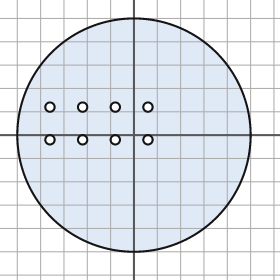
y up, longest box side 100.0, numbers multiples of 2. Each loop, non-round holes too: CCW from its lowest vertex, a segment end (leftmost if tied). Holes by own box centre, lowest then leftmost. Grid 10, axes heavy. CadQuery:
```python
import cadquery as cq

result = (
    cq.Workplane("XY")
    .moveTo(0.0, 0.0)
    .circle(50.0)
    .moveTo(-36.0, -2.0)
    .circle(2.0)
    .moveTo(-22.0, -2.0)
    .circle(2.0)
    .moveTo(-8.0, -2.0)
    .circle(2.0)
    .moveTo(6.0, -2.0)
    .circle(2.0)
    .moveTo(-36.0, 12.0)
    .circle(2.0)
    .moveTo(-22.0, 12.0)
    .circle(2.0)
    .moveTo(-8.0, 12.0)
    .circle(2.0)
    .moveTo(6.0, 12.0)
    .circle(2.0)
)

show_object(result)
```